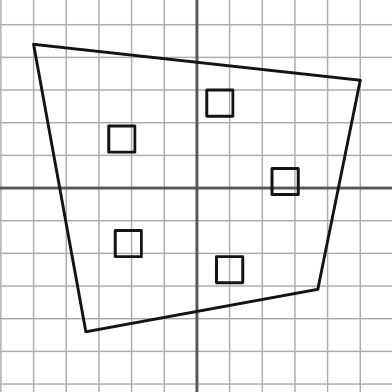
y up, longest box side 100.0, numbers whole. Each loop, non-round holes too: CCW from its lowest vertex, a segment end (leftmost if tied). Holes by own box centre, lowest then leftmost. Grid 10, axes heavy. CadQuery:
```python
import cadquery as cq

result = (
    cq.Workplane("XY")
    .moveTo(-34.0, -44.0)
    .lineTo(37.0, -31.0)
    .lineTo(50.0, 33.0)
    .lineTo(-50.0, 44.0)
    .close()
    .moveTo(6.0, -29.0)
    .lineTo(14.0, -29.0)
    .lineTo(14.0, -21.0)
    .lineTo(6.0, -21.0)
    .close()
    .moveTo(-25.0, -21.0)
    .lineTo(-17.0, -21.0)
    .lineTo(-17.0, -13.0)
    .lineTo(-25.0, -13.0)
    .close()
    .moveTo(23.0, -2.0)
    .lineTo(31.0, -2.0)
    .lineTo(31.0, 6.0)
    .lineTo(23.0, 6.0)
    .close()
    .moveTo(-27.0, 11.0)
    .lineTo(-19.0, 11.0)
    .lineTo(-19.0, 19.0)
    .lineTo(-27.0, 19.0)
    .close()
    .moveTo(3.0, 22.0)
    .lineTo(11.0, 22.0)
    .lineTo(11.0, 30.0)
    .lineTo(3.0, 30.0)
    .close()
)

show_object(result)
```